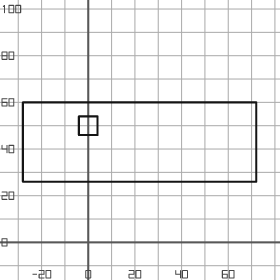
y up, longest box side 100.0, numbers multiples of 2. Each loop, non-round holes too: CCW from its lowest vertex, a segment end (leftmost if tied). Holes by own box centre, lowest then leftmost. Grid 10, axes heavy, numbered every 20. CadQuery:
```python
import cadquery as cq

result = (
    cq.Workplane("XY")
    .moveTo(-28.0, 26.0)
    .lineTo(72.0, 26.0)
    .lineTo(72.0, 60.0)
    .lineTo(-28.0, 60.0)
    .close()
    .moveTo(-4.0, 46.0)
    .lineTo(4.0, 46.0)
    .lineTo(4.0, 54.0)
    .lineTo(-4.0, 54.0)
    .close()
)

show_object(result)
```